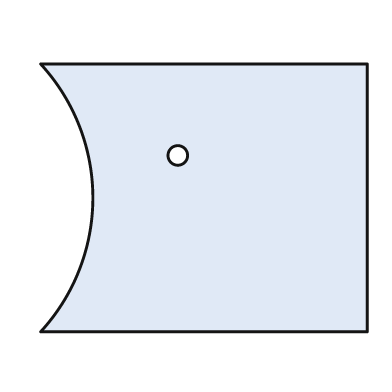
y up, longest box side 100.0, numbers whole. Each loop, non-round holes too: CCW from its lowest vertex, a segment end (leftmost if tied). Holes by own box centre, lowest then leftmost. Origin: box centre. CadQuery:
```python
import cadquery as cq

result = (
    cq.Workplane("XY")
    .moveTo(-50.0, -41.0)
    .lineTo(50.0, -41.0)
    .lineTo(50.0, 41.0)
    .lineTo(-50.0, 41.0)
    .threePointArc((-34.0, 0.0), (-50.0, -41.0))
    .close()
    .moveTo(-8.0, 13.0)
    .circle(3.0)
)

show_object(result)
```